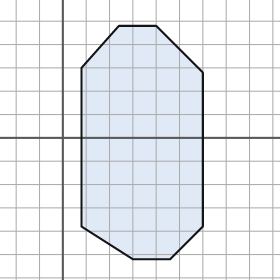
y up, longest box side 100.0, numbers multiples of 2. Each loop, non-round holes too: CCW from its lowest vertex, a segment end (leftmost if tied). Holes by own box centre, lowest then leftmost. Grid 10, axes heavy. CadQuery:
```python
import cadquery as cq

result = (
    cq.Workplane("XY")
    .moveTo(30.0, -52.0)
    .lineTo(46.0, -52.0)
    .lineTo(60.0, -38.0)
    .lineTo(60.0, 28.0)
    .lineTo(40.0, 48.0)
    .lineTo(24.0, 48.0)
    .lineTo(8.0, 30.0)
    .lineTo(8.0, -38.0)
    .close()
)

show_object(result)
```